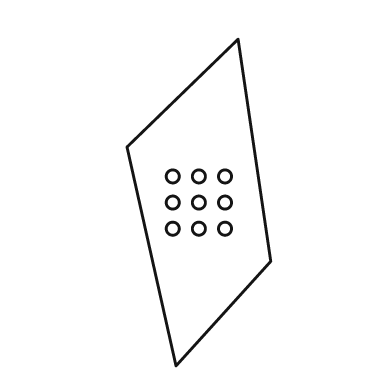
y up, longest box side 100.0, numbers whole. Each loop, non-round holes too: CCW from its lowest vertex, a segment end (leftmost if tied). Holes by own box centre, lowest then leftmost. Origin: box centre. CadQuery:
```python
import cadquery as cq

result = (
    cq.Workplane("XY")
    .moveTo(-7.0, -50.0)
    .lineTo(22.0, -18.0)
    .lineTo(12.0, 50.0)
    .lineTo(-22.0, 17.0)
    .close()
    .moveTo(-8.0, -8.0)
    .circle(2.0)
    .moveTo(0.0, -8.0)
    .circle(2.0)
    .moveTo(8.0, -8.0)
    .circle(2.0)
    .moveTo(-8.0, 0.0)
    .circle(2.0)
    .moveTo(0.0, 0.0)
    .circle(2.0)
    .moveTo(8.0, 0.0)
    .circle(2.0)
    .moveTo(-8.0, 8.0)
    .circle(2.0)
    .moveTo(0.0, 8.0)
    .circle(2.0)
    .moveTo(8.0, 8.0)
    .circle(2.0)
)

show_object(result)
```